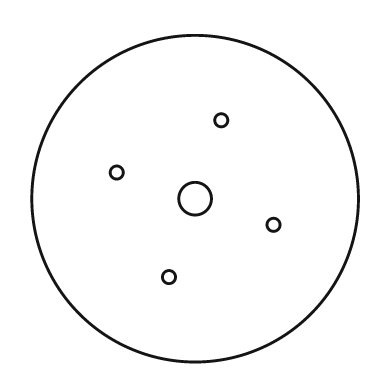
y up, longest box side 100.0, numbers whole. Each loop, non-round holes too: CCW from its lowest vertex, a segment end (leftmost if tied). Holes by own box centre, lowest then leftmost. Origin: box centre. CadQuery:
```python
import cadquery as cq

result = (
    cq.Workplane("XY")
    .moveTo(0.0, 0.0)
    .circle(50.0)
    .moveTo(-8.0, -24.0)
    .circle(2.0)
    .moveTo(24.0, -8.0)
    .circle(2.0)
    .moveTo(0.0, 0.0)
    .circle(5.0)
    .moveTo(-24.0, 8.0)
    .circle(2.0)
    .moveTo(8.0, 24.0)
    .circle(2.0)
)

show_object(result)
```